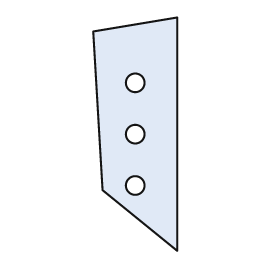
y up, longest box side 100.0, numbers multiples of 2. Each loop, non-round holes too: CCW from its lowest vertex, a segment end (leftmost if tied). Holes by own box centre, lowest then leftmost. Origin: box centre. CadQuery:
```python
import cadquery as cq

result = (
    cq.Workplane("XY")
    .moveTo(18.0, -50.0)
    .lineTo(18.0, 50.0)
    .lineTo(-18.0, 44.0)
    .lineTo(-14.0, -24.0)
    .close()
    .moveTo(0.0, -22.0)
    .circle(4.0)
    .moveTo(0.0, 0.0)
    .circle(4.0)
    .moveTo(0.0, 22.0)
    .circle(4.0)
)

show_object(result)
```